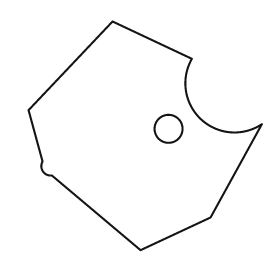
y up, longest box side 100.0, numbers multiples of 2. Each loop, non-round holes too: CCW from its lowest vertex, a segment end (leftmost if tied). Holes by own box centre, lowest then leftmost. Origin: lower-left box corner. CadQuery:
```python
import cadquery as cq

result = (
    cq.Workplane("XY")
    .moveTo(48.0, 0.0)
    .lineTo(78.0, 14.0)
    .lineTo(100.0, 54.0)
    .threePointArc((74.0, 56.0), (70.0, 82.0))
    .lineTo(36.0, 98.0)
    .lineTo(0.0, 60.0)
    .lineTo(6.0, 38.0)
    .threePointArc((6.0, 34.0), (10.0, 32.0))
    .close()
    .moveTo(60.0, 52.0)
    .circle(6.0)
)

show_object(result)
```